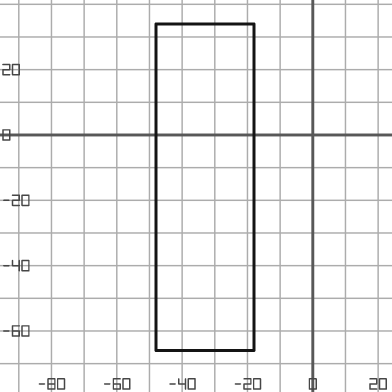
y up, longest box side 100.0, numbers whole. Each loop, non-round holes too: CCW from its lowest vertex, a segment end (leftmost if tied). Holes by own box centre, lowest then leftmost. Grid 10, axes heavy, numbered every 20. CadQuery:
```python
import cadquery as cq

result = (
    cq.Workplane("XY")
    .moveTo(-48.0, -66.0)
    .lineTo(-18.0, -66.0)
    .lineTo(-18.0, 34.0)
    .lineTo(-48.0, 34.0)
    .close()
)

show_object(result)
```